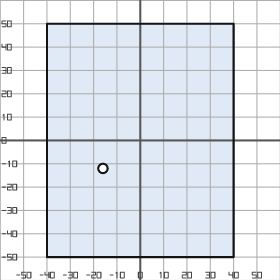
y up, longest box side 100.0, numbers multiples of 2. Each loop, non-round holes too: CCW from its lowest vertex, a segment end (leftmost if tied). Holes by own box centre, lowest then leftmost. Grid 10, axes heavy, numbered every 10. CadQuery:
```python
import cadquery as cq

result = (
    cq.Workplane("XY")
    .moveTo(-40.0, -50.0)
    .lineTo(40.0, -50.0)
    .lineTo(40.0, 50.0)
    .lineTo(-40.0, 50.0)
    .close()
    .moveTo(-16.0, -12.0)
    .circle(2.0)
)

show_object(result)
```